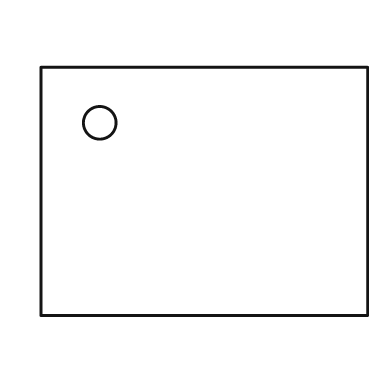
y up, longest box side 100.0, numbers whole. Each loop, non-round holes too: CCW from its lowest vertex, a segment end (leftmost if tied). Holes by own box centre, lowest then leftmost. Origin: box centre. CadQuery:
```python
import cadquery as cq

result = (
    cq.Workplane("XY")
    .moveTo(-50.0, -38.0)
    .lineTo(50.0, -38.0)
    .lineTo(50.0, 38.0)
    .lineTo(-50.0, 38.0)
    .close()
    .moveTo(-32.0, 21.0)
    .circle(5.0)
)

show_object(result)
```